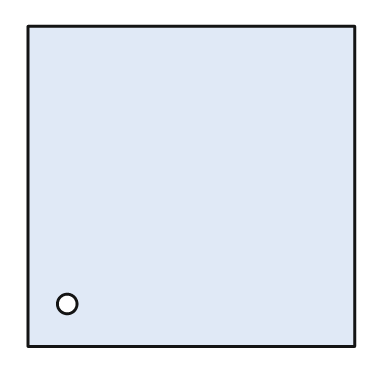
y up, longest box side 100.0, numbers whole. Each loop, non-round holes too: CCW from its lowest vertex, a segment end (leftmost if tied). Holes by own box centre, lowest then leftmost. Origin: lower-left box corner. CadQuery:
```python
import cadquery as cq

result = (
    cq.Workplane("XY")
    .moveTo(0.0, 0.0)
    .lineTo(100.0, 0.0)
    .lineTo(100.0, 98.0)
    .lineTo(0.0, 98.0)
    .close()
    .moveTo(12.0, 13.0)
    .circle(3.0)
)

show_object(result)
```